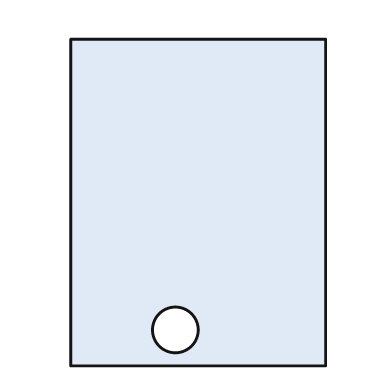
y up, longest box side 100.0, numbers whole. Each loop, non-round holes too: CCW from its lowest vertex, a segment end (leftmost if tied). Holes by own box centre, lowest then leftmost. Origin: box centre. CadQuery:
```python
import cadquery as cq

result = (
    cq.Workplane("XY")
    .moveTo(-39.0, -50.0)
    .lineTo(39.0, -50.0)
    .lineTo(39.0, 50.0)
    .lineTo(-39.0, 50.0)
    .close()
    .moveTo(-7.0, -39.0)
    .circle(7.0)
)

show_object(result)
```